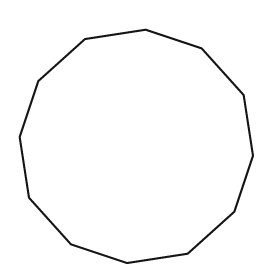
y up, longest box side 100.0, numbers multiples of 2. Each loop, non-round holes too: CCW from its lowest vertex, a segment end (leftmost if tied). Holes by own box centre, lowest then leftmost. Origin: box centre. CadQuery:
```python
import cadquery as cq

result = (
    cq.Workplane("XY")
    .moveTo(-4.0, -50.0)
    .lineTo(22.0, -46.0)
    .lineTo(42.0, -28.0)
    .lineTo(50.0, -4.0)
    .lineTo(46.0, 22.0)
    .lineTo(28.0, 42.0)
    .lineTo(4.0, 50.0)
    .lineTo(-22.0, 46.0)
    .lineTo(-42.0, 28.0)
    .lineTo(-50.0, 4.0)
    .lineTo(-46.0, -22.0)
    .lineTo(-28.0, -42.0)
    .close()
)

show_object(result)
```